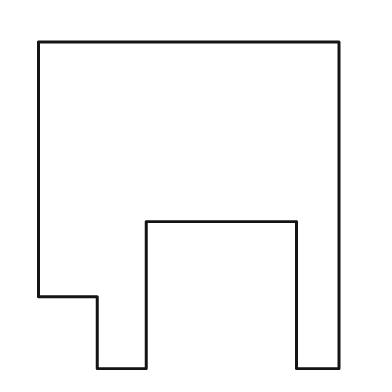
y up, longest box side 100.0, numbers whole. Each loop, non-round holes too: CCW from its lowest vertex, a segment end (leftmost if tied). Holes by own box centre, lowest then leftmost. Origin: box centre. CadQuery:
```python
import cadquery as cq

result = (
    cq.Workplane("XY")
    .moveTo(-28.0, -50.0)
    .lineTo(-13.0, -50.0)
    .lineTo(-13.0, -5.0)
    .lineTo(33.0, -5.0)
    .lineTo(33.0, -50.0)
    .lineTo(46.0, -50.0)
    .lineTo(46.0, 50.0)
    .lineTo(-46.0, 50.0)
    .lineTo(-46.0, -28.0)
    .lineTo(-28.0, -28.0)
    .close()
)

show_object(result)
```